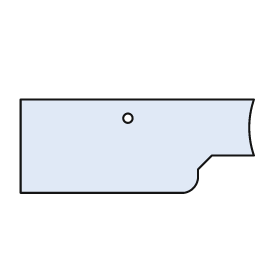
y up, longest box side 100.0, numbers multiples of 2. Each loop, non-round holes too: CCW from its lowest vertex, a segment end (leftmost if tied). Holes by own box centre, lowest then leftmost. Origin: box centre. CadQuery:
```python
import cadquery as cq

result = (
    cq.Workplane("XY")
    .moveTo(-50.0, -20.0)
    .lineTo(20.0, -20.0)
    .threePointArc((24.0, -18.0), (26.0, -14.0))
    .lineTo(26.0, -10.0)
    .lineTo(32.0, -4.0)
    .lineTo(50.0, -4.0)
    .threePointArc((48.0, 8.0), (50.0, 20.0))
    .lineTo(-50.0, 20.0)
    .close()
    .moveTo(-4.0, 12.0)
    .circle(2.0)
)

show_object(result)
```